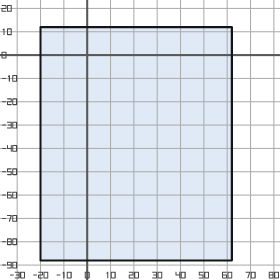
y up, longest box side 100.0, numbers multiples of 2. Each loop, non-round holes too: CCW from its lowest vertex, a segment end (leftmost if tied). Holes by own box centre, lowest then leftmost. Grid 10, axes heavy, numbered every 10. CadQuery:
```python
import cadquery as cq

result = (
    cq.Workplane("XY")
    .moveTo(-20.0, -88.0)
    .lineTo(62.0, -88.0)
    .lineTo(62.0, 12.0)
    .lineTo(-20.0, 12.0)
    .close()
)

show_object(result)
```